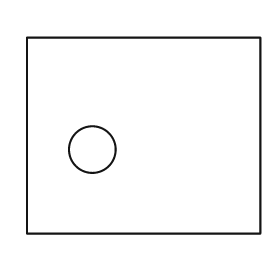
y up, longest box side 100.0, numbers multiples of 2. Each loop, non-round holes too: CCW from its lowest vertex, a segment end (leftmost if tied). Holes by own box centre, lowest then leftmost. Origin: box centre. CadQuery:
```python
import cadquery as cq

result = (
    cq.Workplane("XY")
    .moveTo(-50.0, -42.0)
    .lineTo(50.0, -42.0)
    .lineTo(50.0, 42.0)
    .lineTo(-50.0, 42.0)
    .close()
    .moveTo(-22.0, -6.0)
    .circle(10.0)
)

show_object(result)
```